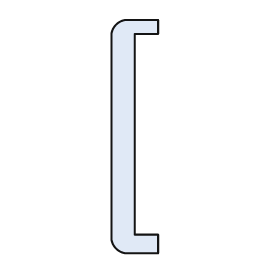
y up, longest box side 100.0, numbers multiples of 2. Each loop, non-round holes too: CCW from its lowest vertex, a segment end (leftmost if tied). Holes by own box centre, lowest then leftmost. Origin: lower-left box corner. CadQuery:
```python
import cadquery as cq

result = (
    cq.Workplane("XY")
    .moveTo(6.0, 0.0)
    .lineTo(20.0, 0.0)
    .lineTo(20.0, 8.0)
    .lineTo(10.0, 8.0)
    .lineTo(10.0, 94.0)
    .lineTo(20.0, 94.0)
    .lineTo(20.0, 100.0)
    .lineTo(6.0, 100.0)
    .threePointArc((2.0, 98.0), (0.0, 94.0))
    .lineTo(0.0, 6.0)
    .threePointArc((2.0, 2.0), (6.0, 0.0))
    .close()
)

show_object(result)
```